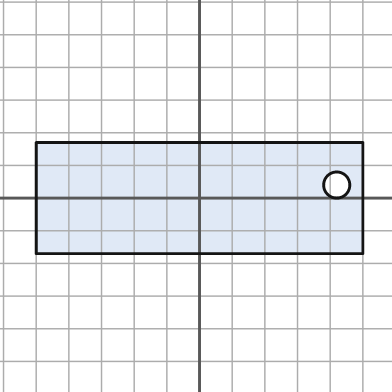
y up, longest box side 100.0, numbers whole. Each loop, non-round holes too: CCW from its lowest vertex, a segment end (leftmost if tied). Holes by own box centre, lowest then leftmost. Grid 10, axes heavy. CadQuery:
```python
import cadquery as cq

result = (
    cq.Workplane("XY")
    .moveTo(-50.0, -17.0)
    .lineTo(50.0, -17.0)
    .lineTo(50.0, 17.0)
    .lineTo(-50.0, 17.0)
    .close()
    .moveTo(42.0, 4.0)
    .circle(4.0)
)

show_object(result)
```